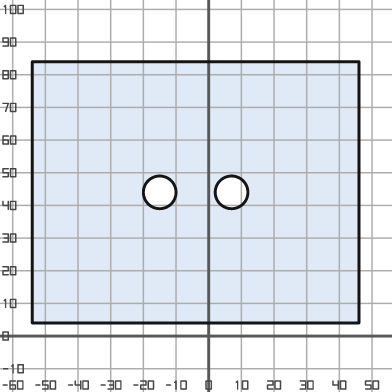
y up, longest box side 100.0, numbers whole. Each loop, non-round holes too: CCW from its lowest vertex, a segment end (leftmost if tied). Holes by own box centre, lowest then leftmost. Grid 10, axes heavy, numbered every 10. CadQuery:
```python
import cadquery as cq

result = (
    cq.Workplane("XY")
    .moveTo(-54.0, 4.0)
    .lineTo(46.0, 4.0)
    .lineTo(46.0, 84.0)
    .lineTo(-54.0, 84.0)
    .close()
    .moveTo(-15.0, 44.0)
    .circle(5.0)
    .moveTo(7.0, 44.0)
    .circle(5.0)
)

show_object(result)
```